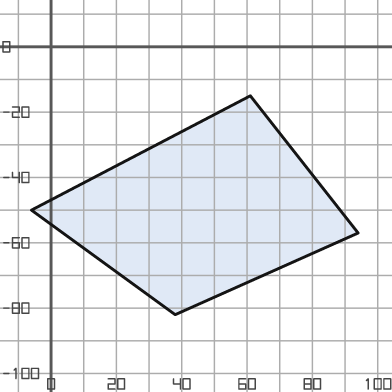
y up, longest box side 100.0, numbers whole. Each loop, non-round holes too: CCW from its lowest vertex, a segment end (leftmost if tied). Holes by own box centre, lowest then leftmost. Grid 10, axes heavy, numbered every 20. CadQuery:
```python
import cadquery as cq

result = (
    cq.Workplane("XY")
    .moveTo(38.0, -82.0)
    .lineTo(94.0, -57.0)
    .lineTo(61.0, -15.0)
    .lineTo(-6.0, -50.0)
    .close()
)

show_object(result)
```